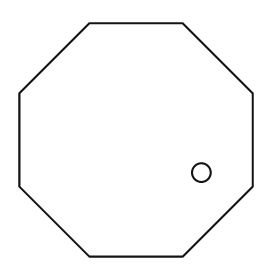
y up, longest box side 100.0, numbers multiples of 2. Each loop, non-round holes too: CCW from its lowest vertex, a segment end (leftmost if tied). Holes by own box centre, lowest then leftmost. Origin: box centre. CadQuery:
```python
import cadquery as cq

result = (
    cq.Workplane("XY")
    .moveTo(-20.0, -50.0)
    .lineTo(20.0, -50.0)
    .lineTo(50.0, -20.0)
    .lineTo(50.0, 20.0)
    .lineTo(20.0, 50.0)
    .lineTo(-20.0, 50.0)
    .lineTo(-50.0, 20.0)
    .lineTo(-50.0, -20.0)
    .close()
    .moveTo(28.0, -14.0)
    .circle(4.0)
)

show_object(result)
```